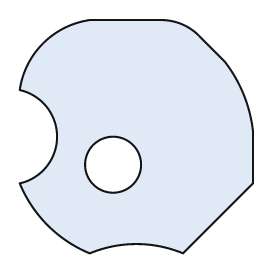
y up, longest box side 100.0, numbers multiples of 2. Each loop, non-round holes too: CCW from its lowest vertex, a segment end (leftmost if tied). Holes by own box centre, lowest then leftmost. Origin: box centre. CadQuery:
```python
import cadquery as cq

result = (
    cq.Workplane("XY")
    .moveTo(-20.0, -50.0)
    .threePointArc((0.0, -46.0), (20.0, -50.0))
    .lineTo(50.0, -20.0)
    .lineTo(50.0, 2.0)
    .threePointArc((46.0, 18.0), (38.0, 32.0))
    .lineTo(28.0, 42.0)
    .threePointArc((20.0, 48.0), (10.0, 50.0))
    .lineTo(-20.0, 50.0)
    .threePointArc((-40.0, 40.0), (-50.0, 20.0))
    .threePointArc((-34.0, 0.0), (-50.0, -20.0))
    .threePointArc((-38.0, -38.0), (-20.0, -50.0))
    .close()
    .moveTo(-10.0, -12.0)
    .circle(12.0)
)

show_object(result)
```